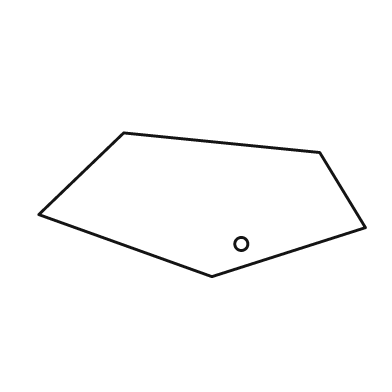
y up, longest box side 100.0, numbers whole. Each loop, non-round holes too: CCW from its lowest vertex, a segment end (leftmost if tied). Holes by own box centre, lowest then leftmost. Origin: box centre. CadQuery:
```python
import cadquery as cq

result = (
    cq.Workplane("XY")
    .moveTo(3.0, -22.0)
    .lineTo(50.0, -7.0)
    .lineTo(36.0, 16.0)
    .lineTo(-24.0, 22.0)
    .lineTo(-50.0, -3.0)
    .close()
    .moveTo(12.0, -12.0)
    .circle(2.0)
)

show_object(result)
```